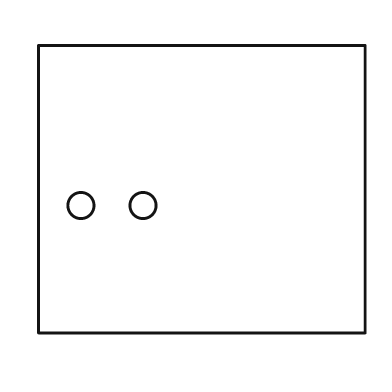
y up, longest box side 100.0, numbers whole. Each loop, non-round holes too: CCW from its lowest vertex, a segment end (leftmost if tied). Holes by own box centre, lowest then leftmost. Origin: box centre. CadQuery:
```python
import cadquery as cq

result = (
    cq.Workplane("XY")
    .moveTo(-50.0, -44.0)
    .lineTo(50.0, -44.0)
    .lineTo(50.0, 44.0)
    .lineTo(-50.0, 44.0)
    .close()
    .moveTo(-37.0, -5.0)
    .circle(4.0)
    .moveTo(-18.0, -5.0)
    .circle(4.0)
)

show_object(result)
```